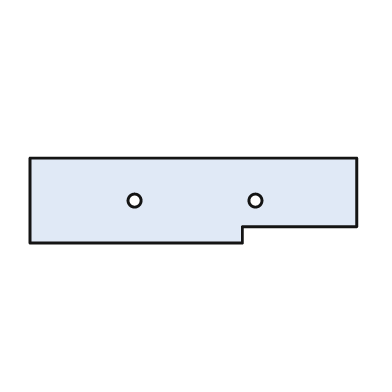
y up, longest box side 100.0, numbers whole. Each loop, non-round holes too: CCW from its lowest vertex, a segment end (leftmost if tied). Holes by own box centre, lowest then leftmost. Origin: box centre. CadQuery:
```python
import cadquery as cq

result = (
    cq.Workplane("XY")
    .moveTo(-50.0, -13.0)
    .lineTo(15.0, -13.0)
    .lineTo(15.0, -8.0)
    .lineTo(50.0, -8.0)
    .lineTo(50.0, 13.0)
    .lineTo(-50.0, 13.0)
    .close()
    .moveTo(-18.0, 0.0)
    .circle(2.0)
    .moveTo(19.0, 0.0)
    .circle(2.0)
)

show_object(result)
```